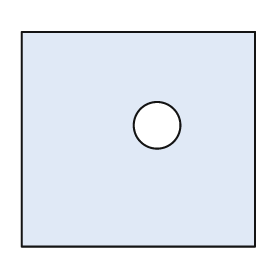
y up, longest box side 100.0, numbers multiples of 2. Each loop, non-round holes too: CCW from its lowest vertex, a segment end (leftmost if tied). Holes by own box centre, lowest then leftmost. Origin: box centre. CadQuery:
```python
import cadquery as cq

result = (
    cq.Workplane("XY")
    .moveTo(-50.0, -46.0)
    .lineTo(50.0, -46.0)
    .lineTo(50.0, 46.0)
    .lineTo(-50.0, 46.0)
    .close()
    .moveTo(8.0, 6.0)
    .circle(10.0)
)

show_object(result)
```